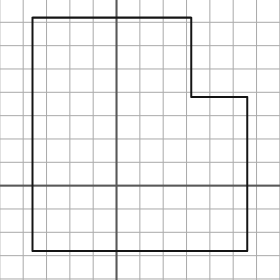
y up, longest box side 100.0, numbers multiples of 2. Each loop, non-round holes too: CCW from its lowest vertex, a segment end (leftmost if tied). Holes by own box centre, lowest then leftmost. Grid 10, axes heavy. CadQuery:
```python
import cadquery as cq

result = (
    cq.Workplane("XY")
    .moveTo(-36.0, -28.0)
    .lineTo(56.0, -28.0)
    .lineTo(56.0, 38.0)
    .lineTo(32.0, 38.0)
    .lineTo(32.0, 72.0)
    .lineTo(-36.0, 72.0)
    .close()
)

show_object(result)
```